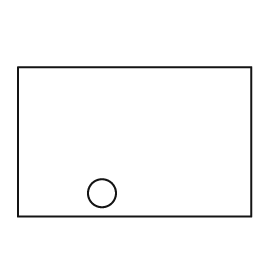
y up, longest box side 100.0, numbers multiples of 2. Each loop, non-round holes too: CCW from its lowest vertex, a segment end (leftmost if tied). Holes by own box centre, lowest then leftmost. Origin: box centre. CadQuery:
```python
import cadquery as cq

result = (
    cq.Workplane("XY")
    .moveTo(-50.0, -32.0)
    .lineTo(50.0, -32.0)
    .lineTo(50.0, 32.0)
    .lineTo(-50.0, 32.0)
    .close()
    .moveTo(-14.0, -22.0)
    .circle(6.0)
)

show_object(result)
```